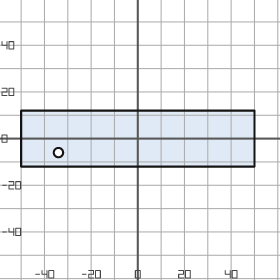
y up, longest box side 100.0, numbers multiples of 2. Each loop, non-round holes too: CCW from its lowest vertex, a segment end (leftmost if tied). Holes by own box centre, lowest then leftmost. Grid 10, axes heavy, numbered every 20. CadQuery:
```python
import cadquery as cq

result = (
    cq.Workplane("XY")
    .moveTo(-50.0, -12.0)
    .lineTo(50.0, -12.0)
    .lineTo(50.0, 12.0)
    .lineTo(-50.0, 12.0)
    .close()
    .moveTo(-34.0, -6.0)
    .circle(2.0)
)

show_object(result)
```